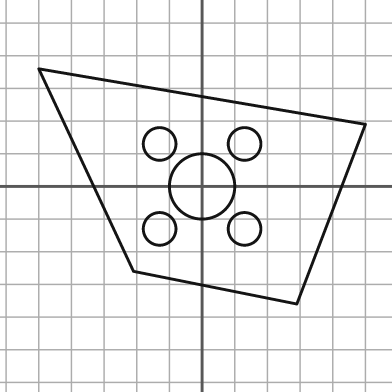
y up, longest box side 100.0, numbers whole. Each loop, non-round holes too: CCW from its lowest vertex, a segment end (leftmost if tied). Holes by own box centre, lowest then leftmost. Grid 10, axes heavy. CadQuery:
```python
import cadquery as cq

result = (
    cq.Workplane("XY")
    .moveTo(29.0, -36.0)
    .lineTo(50.0, 19.0)
    .lineTo(-50.0, 36.0)
    .lineTo(-21.0, -26.0)
    .close()
    .moveTo(-13.0, -13.0)
    .circle(5.0)
    .moveTo(13.0, -13.0)
    .circle(5.0)
    .moveTo(0.0, 0.0)
    .circle(10.0)
    .moveTo(-13.0, 13.0)
    .circle(5.0)
    .moveTo(13.0, 13.0)
    .circle(5.0)
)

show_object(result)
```